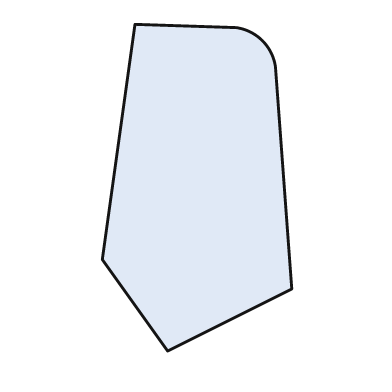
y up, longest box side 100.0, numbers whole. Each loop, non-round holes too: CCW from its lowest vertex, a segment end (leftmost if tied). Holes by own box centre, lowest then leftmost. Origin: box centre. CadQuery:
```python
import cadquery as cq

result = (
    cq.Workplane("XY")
    .moveTo(-9.0, -50.0)
    .lineTo(29.0, -31.0)
    .lineTo(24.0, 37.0)
    .threePointArc((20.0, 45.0), (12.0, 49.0))
    .lineTo(-19.0, 50.0)
    .lineTo(-29.0, -22.0)
    .close()
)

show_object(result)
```